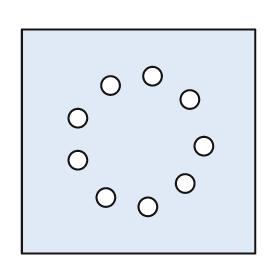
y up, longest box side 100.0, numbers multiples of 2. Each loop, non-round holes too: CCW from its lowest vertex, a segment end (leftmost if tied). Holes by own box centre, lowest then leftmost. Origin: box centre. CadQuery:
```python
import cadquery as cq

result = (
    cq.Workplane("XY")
    .moveTo(-50.0, -48.0)
    .lineTo(50.0, -48.0)
    .lineTo(50.0, 48.0)
    .lineTo(-50.0, 48.0)
    .close()
    .moveTo(4.0, -28.0)
    .circle(4.0)
    .moveTo(-14.0, -24.0)
    .circle(4.0)
    .moveTo(20.0, -18.0)
    .circle(4.0)
    .moveTo(-26.0, -8.0)
    .circle(4.0)
    .moveTo(28.0, -2.0)
    .circle(4.0)
    .moveTo(-26.0, 10.0)
    .circle(4.0)
    .moveTo(22.0, 18.0)
    .circle(4.0)
    .moveTo(-12.0, 24.0)
    .circle(4.0)
    .moveTo(6.0, 28.0)
    .circle(4.0)
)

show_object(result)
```